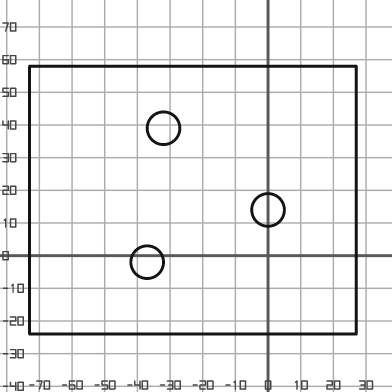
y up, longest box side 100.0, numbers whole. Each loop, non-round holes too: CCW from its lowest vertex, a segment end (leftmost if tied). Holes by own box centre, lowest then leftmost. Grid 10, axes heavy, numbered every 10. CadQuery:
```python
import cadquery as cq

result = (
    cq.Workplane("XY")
    .moveTo(-73.0, -24.0)
    .lineTo(27.0, -24.0)
    .lineTo(27.0, 58.0)
    .lineTo(-73.0, 58.0)
    .close()
    .moveTo(-37.0, -2.0)
    .circle(5.0)
    .moveTo(0.0, 14.0)
    .circle(5.0)
    .moveTo(-32.0, 39.0)
    .circle(5.0)
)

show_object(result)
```